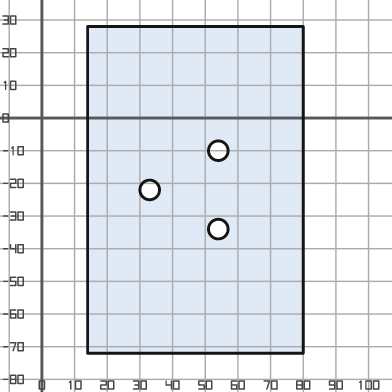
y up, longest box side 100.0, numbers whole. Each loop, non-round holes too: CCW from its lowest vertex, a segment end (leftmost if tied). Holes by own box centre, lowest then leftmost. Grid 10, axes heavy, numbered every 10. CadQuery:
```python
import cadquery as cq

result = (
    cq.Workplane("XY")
    .moveTo(14.0, -72.0)
    .lineTo(80.0, -72.0)
    .lineTo(80.0, 28.0)
    .lineTo(14.0, 28.0)
    .close()
    .moveTo(54.0, -34.0)
    .circle(3.0)
    .moveTo(33.0, -22.0)
    .circle(3.0)
    .moveTo(54.0, -10.0)
    .circle(3.0)
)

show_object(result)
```